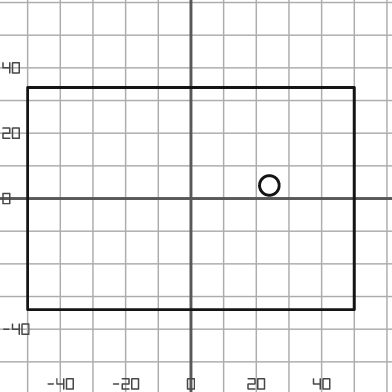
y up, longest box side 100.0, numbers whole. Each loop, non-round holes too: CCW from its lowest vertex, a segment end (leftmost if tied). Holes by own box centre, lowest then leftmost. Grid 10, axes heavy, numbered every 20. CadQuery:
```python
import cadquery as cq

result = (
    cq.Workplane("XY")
    .moveTo(-50.0, -34.0)
    .lineTo(50.0, -34.0)
    .lineTo(50.0, 34.0)
    .lineTo(-50.0, 34.0)
    .close()
    .moveTo(24.0, 4.0)
    .circle(3.0)
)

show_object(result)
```